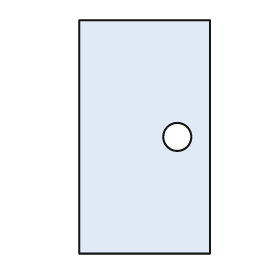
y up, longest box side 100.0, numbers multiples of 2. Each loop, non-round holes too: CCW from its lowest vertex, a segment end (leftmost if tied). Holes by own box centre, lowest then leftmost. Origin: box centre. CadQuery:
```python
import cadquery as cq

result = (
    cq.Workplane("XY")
    .moveTo(-28.0, -50.0)
    .lineTo(28.0, -50.0)
    .lineTo(28.0, 50.0)
    .lineTo(-28.0, 50.0)
    .close()
    .moveTo(14.0, 0.0)
    .circle(6.0)
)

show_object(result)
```